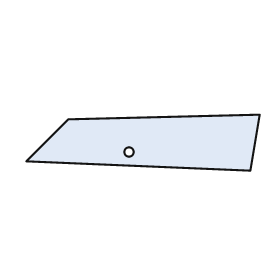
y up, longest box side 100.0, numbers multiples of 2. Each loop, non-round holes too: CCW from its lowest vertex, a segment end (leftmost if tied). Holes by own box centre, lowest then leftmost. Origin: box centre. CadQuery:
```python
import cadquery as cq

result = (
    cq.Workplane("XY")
    .moveTo(46.0, -12.0)
    .lineTo(50.0, 12.0)
    .lineTo(-32.0, 10.0)
    .lineTo(-50.0, -8.0)
    .close()
    .moveTo(-6.0, -4.0)
    .circle(2.0)
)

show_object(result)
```